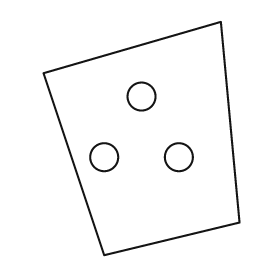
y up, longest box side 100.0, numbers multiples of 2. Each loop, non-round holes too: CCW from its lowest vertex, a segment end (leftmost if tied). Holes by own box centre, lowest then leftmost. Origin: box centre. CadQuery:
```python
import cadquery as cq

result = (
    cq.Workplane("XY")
    .moveTo(-16.0, -50.0)
    .lineTo(42.0, -36.0)
    .lineTo(34.0, 50.0)
    .lineTo(-42.0, 28.0)
    .close()
    .moveTo(-16.0, -8.0)
    .circle(6.0)
    .moveTo(16.0, -8.0)
    .circle(6.0)
    .moveTo(0.0, 18.0)
    .circle(6.0)
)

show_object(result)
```